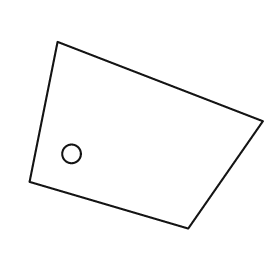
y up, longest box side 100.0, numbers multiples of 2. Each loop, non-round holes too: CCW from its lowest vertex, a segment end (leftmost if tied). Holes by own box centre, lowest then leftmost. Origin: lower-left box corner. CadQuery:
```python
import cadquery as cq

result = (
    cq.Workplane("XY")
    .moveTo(68.0, 0.0)
    .lineTo(100.0, 46.0)
    .lineTo(12.0, 80.0)
    .lineTo(0.0, 20.0)
    .close()
    .moveTo(18.0, 32.0)
    .circle(4.0)
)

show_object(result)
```